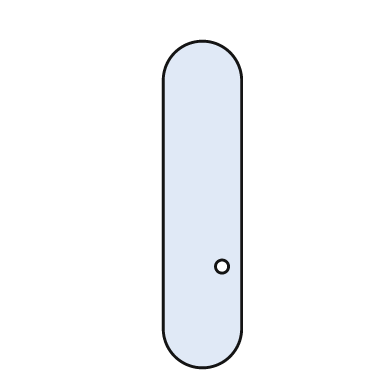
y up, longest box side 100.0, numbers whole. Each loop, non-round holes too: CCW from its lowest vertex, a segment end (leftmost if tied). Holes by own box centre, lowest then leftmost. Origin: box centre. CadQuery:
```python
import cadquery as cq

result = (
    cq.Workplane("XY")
    .moveTo(-12.0, -38.0)
    .threePointArc((0.0, -50.0), (12.0, -38.0))
    .lineTo(12.0, 38.0)
    .threePointArc((0.0, 50.0), (-12.0, 38.0))
    .close()
    .moveTo(6.0, -19.0)
    .circle(2.0)
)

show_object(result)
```